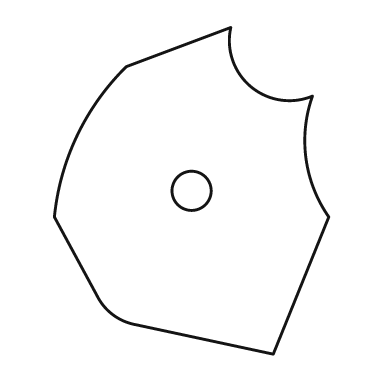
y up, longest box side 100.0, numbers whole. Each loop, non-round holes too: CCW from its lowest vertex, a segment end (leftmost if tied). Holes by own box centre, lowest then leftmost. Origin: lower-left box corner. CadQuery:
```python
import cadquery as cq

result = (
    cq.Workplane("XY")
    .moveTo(67.0, 0.0)
    .lineTo(84.0, 42.0)
    .threePointArc((77.0, 60.0), (79.0, 79.0))
    .threePointArc((60.0, 82.0), (54.0, 100.0))
    .lineTo(22.0, 88.0)
    .threePointArc((7.0, 67.0), (0.0, 42.0))
    .lineTo(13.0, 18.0)
    .threePointArc((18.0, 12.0), (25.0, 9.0))
    .close()
    .moveTo(42.0, 50.0)
    .circle(6.0)
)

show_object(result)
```